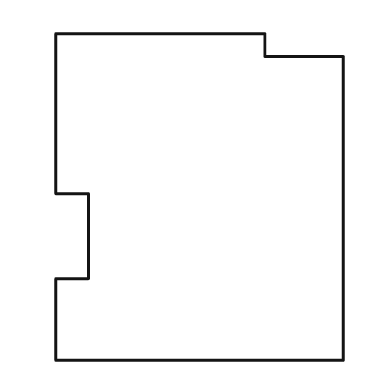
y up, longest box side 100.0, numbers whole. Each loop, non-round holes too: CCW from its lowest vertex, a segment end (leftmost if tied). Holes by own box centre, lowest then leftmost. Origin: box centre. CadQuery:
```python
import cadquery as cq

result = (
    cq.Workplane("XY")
    .moveTo(-44.0, -50.0)
    .lineTo(44.0, -50.0)
    .lineTo(44.0, 43.0)
    .lineTo(20.0, 43.0)
    .lineTo(20.0, 50.0)
    .lineTo(-44.0, 50.0)
    .lineTo(-44.0, 1.0)
    .lineTo(-34.0, 1.0)
    .lineTo(-34.0, -25.0)
    .lineTo(-44.0, -25.0)
    .close()
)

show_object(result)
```